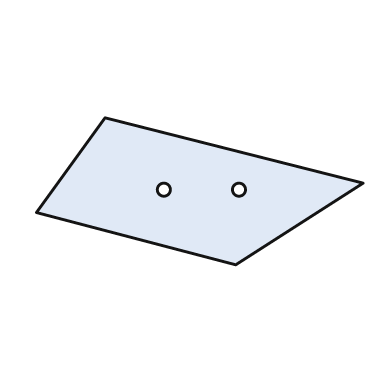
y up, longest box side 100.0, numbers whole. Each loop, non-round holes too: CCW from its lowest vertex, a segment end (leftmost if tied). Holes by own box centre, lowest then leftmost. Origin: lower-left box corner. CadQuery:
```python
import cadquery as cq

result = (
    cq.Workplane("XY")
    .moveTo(61.0, 0.0)
    .lineTo(100.0, 25.0)
    .lineTo(21.0, 45.0)
    .lineTo(0.0, 16.0)
    .close()
    .moveTo(39.0, 23.0)
    .circle(2.0)
    .moveTo(62.0, 23.0)
    .circle(2.0)
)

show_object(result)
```